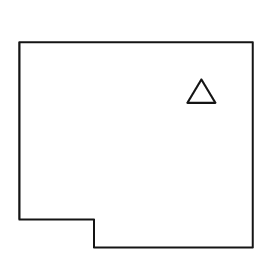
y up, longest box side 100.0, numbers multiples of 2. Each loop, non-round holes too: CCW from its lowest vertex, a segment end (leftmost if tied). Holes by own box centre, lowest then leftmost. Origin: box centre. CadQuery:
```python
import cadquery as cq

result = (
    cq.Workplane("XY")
    .moveTo(-18.0, -44.0)
    .lineTo(50.0, -44.0)
    .lineTo(50.0, 44.0)
    .lineTo(-50.0, 44.0)
    .lineTo(-50.0, -32.0)
    .lineTo(-18.0, -32.0)
    .close()
    .moveTo(22.0, 18.0)
    .lineTo(34.0, 18.0)
    .lineTo(28.0, 28.0)
    .close()
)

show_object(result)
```